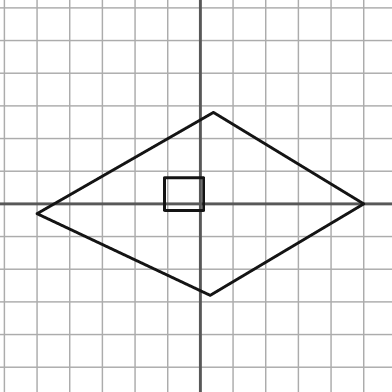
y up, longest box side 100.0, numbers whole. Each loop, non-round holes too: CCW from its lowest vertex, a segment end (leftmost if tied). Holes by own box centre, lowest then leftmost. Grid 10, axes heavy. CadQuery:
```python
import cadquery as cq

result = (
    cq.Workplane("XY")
    .moveTo(3.0, -28.0)
    .lineTo(50.0, 0.0)
    .lineTo(4.0, 28.0)
    .lineTo(-50.0, -3.0)
    .close()
    .moveTo(-11.0, -2.0)
    .lineTo(1.0, -2.0)
    .lineTo(1.0, 8.0)
    .lineTo(-11.0, 8.0)
    .close()
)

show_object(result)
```